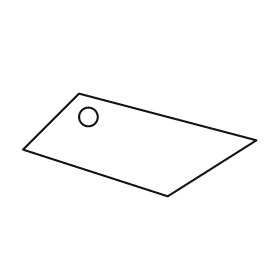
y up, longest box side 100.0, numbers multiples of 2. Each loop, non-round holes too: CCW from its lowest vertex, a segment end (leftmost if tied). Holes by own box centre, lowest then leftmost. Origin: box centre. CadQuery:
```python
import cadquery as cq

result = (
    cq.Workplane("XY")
    .moveTo(12.0, -22.0)
    .lineTo(50.0, 2.0)
    .lineTo(-26.0, 22.0)
    .lineTo(-50.0, -2.0)
    .close()
    .moveTo(-22.0, 12.0)
    .circle(4.0)
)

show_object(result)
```